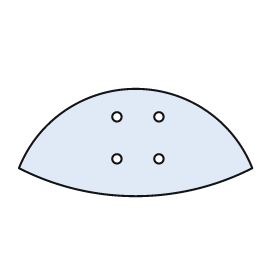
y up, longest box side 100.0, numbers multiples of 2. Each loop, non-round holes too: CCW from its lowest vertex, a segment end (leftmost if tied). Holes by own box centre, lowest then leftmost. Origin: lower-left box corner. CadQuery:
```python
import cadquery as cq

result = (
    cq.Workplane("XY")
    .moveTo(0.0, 12.0)
    .threePointArc((50.0, 0.0), (100.0, 12.0))
    .threePointArc((50.0, 46.0), (0.0, 12.0))
    .close()
    .moveTo(42.0, 16.0)
    .circle(2.0)
    .moveTo(60.0, 16.0)
    .circle(2.0)
    .moveTo(42.0, 34.0)
    .circle(2.0)
    .moveTo(60.0, 34.0)
    .circle(2.0)
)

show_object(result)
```